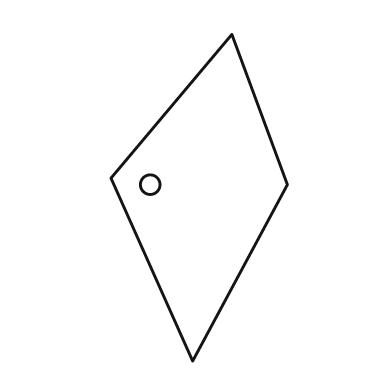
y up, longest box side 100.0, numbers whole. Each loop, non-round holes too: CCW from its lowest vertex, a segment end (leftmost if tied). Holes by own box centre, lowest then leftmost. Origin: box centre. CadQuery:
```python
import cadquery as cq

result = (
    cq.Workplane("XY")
    .moveTo(-2.0, -50.0)
    .lineTo(27.0, 4.0)
    .lineTo(10.0, 50.0)
    .lineTo(-27.0, 6.0)
    .close()
    .moveTo(-15.0, 4.0)
    .circle(3.0)
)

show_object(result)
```